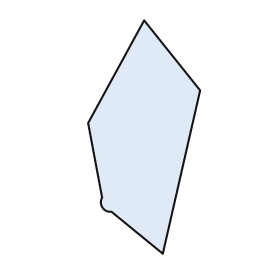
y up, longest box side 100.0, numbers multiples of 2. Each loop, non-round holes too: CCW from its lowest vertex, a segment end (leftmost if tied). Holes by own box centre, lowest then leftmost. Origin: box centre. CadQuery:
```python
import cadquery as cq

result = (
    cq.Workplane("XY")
    .moveTo(8.0, -50.0)
    .lineTo(24.0, 20.0)
    .lineTo(0.0, 50.0)
    .lineTo(-24.0, 6.0)
    .lineTo(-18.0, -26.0)
    .threePointArc((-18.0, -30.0), (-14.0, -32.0))
    .close()
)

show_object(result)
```